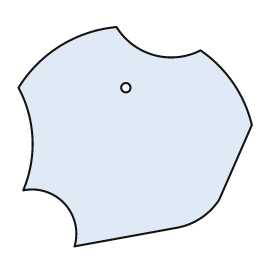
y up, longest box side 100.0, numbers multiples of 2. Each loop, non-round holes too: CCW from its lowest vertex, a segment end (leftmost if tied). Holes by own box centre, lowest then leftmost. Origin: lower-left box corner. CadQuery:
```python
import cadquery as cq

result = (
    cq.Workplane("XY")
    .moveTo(24.0, 0.0)
    .lineTo(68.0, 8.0)
    .threePointArc((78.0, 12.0), (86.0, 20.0))
    .lineTo(100.0, 52.0)
    .threePointArc((92.0, 70.0), (78.0, 84.0))
    .threePointArc((58.0, 82.0), (42.0, 94.0))
    .threePointArc((18.0, 86.0), (0.0, 68.0))
    .threePointArc((6.0, 46.0), (2.0, 24.0))
    .threePointArc((20.0, 18.0), (24.0, 0.0))
    .close()
    .moveTo(46.0, 68.0)
    .circle(2.0)
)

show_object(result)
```